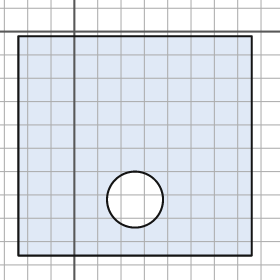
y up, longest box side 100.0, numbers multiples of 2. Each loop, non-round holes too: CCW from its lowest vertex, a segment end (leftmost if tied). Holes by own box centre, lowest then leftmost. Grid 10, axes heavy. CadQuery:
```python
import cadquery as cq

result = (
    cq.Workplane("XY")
    .moveTo(-24.0, -96.0)
    .lineTo(76.0, -96.0)
    .lineTo(76.0, -2.0)
    .lineTo(-24.0, -2.0)
    .close()
    .moveTo(26.0, -72.0)
    .circle(12.0)
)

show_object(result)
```